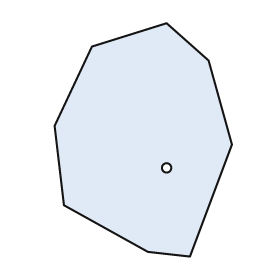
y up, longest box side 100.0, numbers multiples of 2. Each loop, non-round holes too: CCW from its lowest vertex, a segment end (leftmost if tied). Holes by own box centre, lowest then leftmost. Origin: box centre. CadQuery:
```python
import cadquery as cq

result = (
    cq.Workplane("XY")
    .moveTo(20.0, -50.0)
    .lineTo(38.0, -2.0)
    .lineTo(28.0, 34.0)
    .lineTo(10.0, 50.0)
    .lineTo(-22.0, 40.0)
    .lineTo(-38.0, 6.0)
    .lineTo(-34.0, -28.0)
    .lineTo(2.0, -48.0)
    .close()
    .moveTo(10.0, -12.0)
    .circle(2.0)
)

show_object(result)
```